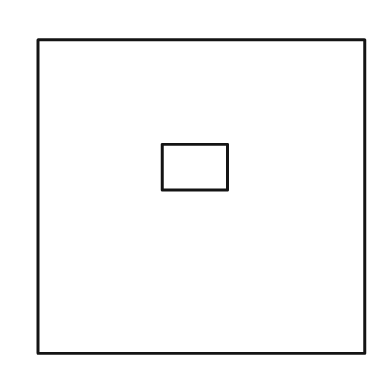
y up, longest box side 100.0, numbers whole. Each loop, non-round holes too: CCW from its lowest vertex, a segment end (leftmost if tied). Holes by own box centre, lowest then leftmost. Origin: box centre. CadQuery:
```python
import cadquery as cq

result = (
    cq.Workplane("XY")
    .moveTo(-50.0, -48.0)
    .lineTo(50.0, -48.0)
    .lineTo(50.0, 48.0)
    .lineTo(-50.0, 48.0)
    .close()
    .moveTo(-12.0, 2.0)
    .lineTo(8.0, 2.0)
    .lineTo(8.0, 16.0)
    .lineTo(-12.0, 16.0)
    .close()
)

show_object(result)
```